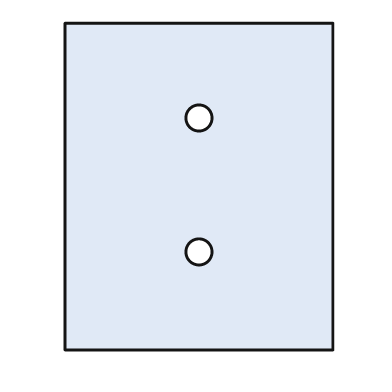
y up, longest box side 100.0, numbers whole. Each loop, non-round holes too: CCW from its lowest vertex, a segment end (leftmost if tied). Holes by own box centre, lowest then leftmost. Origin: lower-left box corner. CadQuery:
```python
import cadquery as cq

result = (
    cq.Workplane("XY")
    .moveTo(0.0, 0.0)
    .lineTo(82.0, 0.0)
    .lineTo(82.0, 100.0)
    .lineTo(0.0, 100.0)
    .close()
    .moveTo(41.0, 30.0)
    .circle(4.0)
    .moveTo(41.0, 71.0)
    .circle(4.0)
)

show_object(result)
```